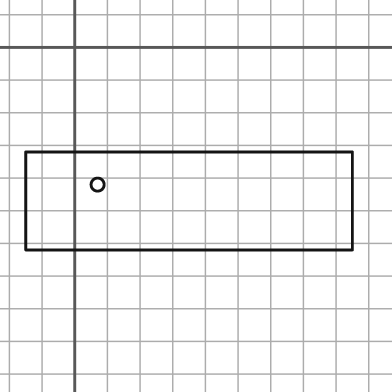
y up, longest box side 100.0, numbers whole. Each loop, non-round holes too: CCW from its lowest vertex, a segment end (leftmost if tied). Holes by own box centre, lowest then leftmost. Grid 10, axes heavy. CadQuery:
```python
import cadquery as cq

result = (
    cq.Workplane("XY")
    .moveTo(-15.0, -62.0)
    .lineTo(85.0, -62.0)
    .lineTo(85.0, -32.0)
    .lineTo(-15.0, -32.0)
    .close()
    .moveTo(7.0, -42.0)
    .circle(2.0)
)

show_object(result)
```